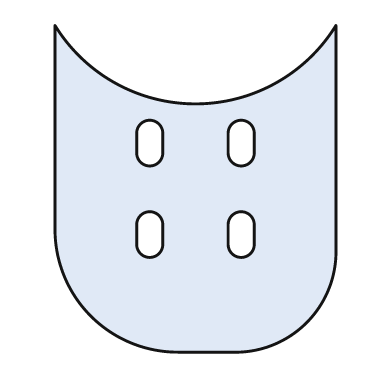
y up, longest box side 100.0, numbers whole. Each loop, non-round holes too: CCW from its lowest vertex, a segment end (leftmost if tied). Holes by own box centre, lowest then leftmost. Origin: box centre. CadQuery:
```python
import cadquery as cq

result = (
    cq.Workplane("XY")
    .moveTo(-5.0, -50.0)
    .lineTo(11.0, -50.0)
    .threePointArc((34.0, -41.0), (43.0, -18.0))
    .lineTo(43.0, 50.0)
    .threePointArc((0.0, 26.0), (-43.0, 50.0))
    .lineTo(-43.0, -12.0)
    .threePointArc((-32.0, -39.0), (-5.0, -50.0))
    .close()
    .moveTo(-18.0, -17.0)
    .threePointArc((-14.0, -21.0), (-10.0, -17.0))
    .lineTo(-10.0, -11.0)
    .threePointArc((-14.0, -7.0), (-18.0, -11.0))
    .close()
    .moveTo(10.0, -17.0)
    .threePointArc((14.0, -21.0), (18.0, -17.0))
    .lineTo(18.0, -11.0)
    .threePointArc((14.0, -7.0), (10.0, -11.0))
    .close()
    .moveTo(-18.0, 11.0)
    .threePointArc((-14.0, 7.0), (-10.0, 11.0))
    .lineTo(-10.0, 17.0)
    .threePointArc((-14.0, 21.0), (-18.0, 17.0))
    .close()
    .moveTo(10.0, 11.0)
    .threePointArc((14.0, 7.0), (18.0, 11.0))
    .lineTo(18.0, 17.0)
    .threePointArc((14.0, 21.0), (10.0, 17.0))
    .close()
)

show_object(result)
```